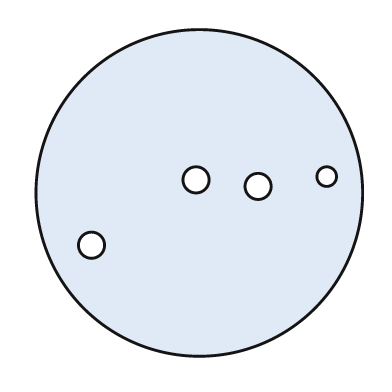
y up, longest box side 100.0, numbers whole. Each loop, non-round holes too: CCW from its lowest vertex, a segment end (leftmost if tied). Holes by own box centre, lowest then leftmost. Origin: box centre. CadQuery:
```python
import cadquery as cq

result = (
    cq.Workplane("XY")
    .moveTo(0.0, 0.0)
    .circle(50.0)
    .moveTo(-33.0, -16.0)
    .circle(4.0)
    .moveTo(18.0, 2.0)
    .circle(4.0)
    .moveTo(-1.0, 4.0)
    .circle(4.0)
    .moveTo(39.0, 5.0)
    .circle(3.0)
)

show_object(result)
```